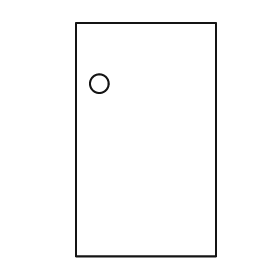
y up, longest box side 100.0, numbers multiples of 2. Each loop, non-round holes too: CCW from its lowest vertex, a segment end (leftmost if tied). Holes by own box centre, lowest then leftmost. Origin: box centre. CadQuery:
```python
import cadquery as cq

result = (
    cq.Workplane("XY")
    .moveTo(-30.0, -50.0)
    .lineTo(30.0, -50.0)
    .lineTo(30.0, 50.0)
    .lineTo(-30.0, 50.0)
    .close()
    .moveTo(-20.0, 24.0)
    .circle(4.0)
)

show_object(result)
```